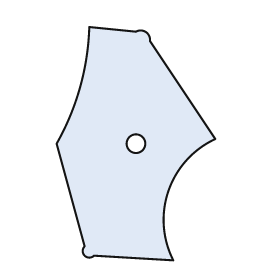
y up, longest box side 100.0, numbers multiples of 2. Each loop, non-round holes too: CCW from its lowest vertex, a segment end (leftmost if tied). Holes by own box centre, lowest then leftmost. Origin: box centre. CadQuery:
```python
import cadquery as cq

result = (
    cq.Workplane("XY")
    .moveTo(16.0, -50.0)
    .threePointArc((14.0, -20.0), (34.0, 2.0))
    .lineTo(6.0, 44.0)
    .threePointArc((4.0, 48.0), (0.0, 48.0))
    .lineTo(-20.0, 50.0)
    .threePointArc((-24.0, 24.0), (-34.0, 0.0))
    .lineTo(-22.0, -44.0)
    .threePointArc((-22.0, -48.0), (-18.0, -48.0))
    .close()
    .moveTo(0.0, 0.0)
    .circle(4.0)
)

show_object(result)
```